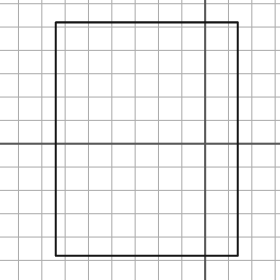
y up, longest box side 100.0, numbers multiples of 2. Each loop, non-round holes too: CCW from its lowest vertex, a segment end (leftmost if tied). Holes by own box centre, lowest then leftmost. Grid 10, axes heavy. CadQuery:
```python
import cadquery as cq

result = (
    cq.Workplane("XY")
    .moveTo(-64.0, -48.0)
    .lineTo(14.0, -48.0)
    .lineTo(14.0, 52.0)
    .lineTo(-64.0, 52.0)
    .close()
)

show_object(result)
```